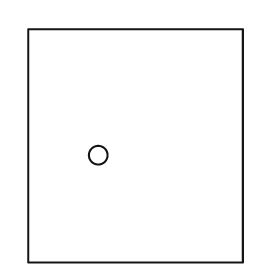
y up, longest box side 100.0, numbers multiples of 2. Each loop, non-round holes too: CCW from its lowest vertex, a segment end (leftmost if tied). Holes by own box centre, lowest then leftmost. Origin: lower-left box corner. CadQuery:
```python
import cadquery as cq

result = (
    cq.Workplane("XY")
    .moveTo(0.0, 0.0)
    .lineTo(92.0, 0.0)
    .lineTo(92.0, 100.0)
    .lineTo(0.0, 100.0)
    .close()
    .moveTo(30.0, 46.0)
    .circle(4.0)
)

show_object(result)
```